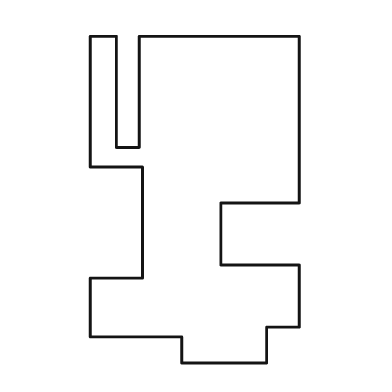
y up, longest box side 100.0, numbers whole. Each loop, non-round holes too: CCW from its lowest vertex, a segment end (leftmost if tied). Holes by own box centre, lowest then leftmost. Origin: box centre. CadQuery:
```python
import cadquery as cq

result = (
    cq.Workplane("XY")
    .moveTo(-4.0, -50.0)
    .lineTo(22.0, -50.0)
    .lineTo(22.0, -39.0)
    .lineTo(32.0, -39.0)
    .lineTo(32.0, -20.0)
    .lineTo(8.0, -20.0)
    .lineTo(8.0, -1.0)
    .lineTo(32.0, -1.0)
    .lineTo(32.0, 50.0)
    .lineTo(-17.0, 50.0)
    .lineTo(-17.0, 16.0)
    .lineTo(-24.0, 16.0)
    .lineTo(-24.0, 50.0)
    .lineTo(-32.0, 50.0)
    .lineTo(-32.0, 10.0)
    .lineTo(-16.0, 10.0)
    .lineTo(-16.0, -24.0)
    .lineTo(-32.0, -24.0)
    .lineTo(-32.0, -42.0)
    .lineTo(-4.0, -42.0)
    .close()
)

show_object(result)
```